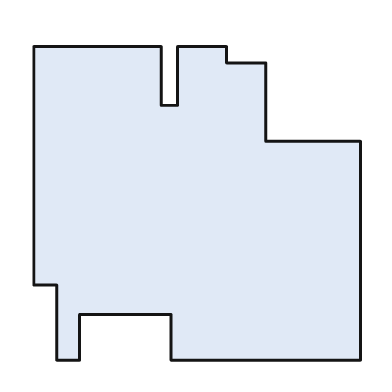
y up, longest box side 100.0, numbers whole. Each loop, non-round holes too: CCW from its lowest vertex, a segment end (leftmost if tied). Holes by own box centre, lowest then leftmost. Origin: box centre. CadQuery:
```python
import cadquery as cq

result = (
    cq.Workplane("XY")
    .moveTo(-43.0, -48.0)
    .lineTo(-36.0, -48.0)
    .lineTo(-36.0, -34.0)
    .lineTo(-8.0, -34.0)
    .lineTo(-8.0, -48.0)
    .lineTo(50.0, -48.0)
    .lineTo(50.0, 19.0)
    .lineTo(21.0, 19.0)
    .lineTo(21.0, 43.0)
    .lineTo(9.0, 43.0)
    .lineTo(9.0, 48.0)
    .lineTo(-6.0, 48.0)
    .lineTo(-6.0, 30.0)
    .lineTo(-11.0, 30.0)
    .lineTo(-11.0, 48.0)
    .lineTo(-50.0, 48.0)
    .lineTo(-50.0, -25.0)
    .lineTo(-43.0, -25.0)
    .close()
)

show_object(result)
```